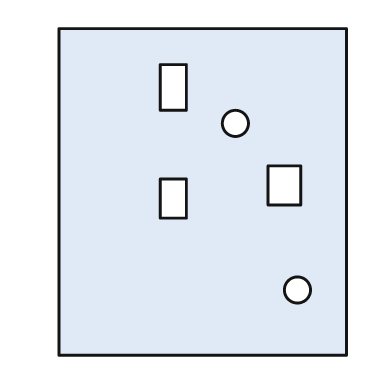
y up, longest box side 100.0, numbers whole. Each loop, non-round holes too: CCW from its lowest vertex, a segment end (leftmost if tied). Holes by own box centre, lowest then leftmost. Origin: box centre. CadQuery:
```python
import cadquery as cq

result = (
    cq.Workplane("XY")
    .moveTo(-44.0, -50.0)
    .lineTo(44.0, -50.0)
    .lineTo(44.0, 50.0)
    .lineTo(-44.0, 50.0)
    .close()
    .moveTo(29.0, -30.0)
    .circle(4.0)
    .moveTo(-13.0, -8.0)
    .lineTo(-5.0, -8.0)
    .lineTo(-5.0, 4.0)
    .lineTo(-13.0, 4.0)
    .close()
    .moveTo(20.0, -4.0)
    .lineTo(30.0, -4.0)
    .lineTo(30.0, 8.0)
    .lineTo(20.0, 8.0)
    .close()
    .moveTo(10.0, 21.0)
    .circle(4.0)
    .moveTo(-13.0, 25.0)
    .lineTo(-5.0, 25.0)
    .lineTo(-5.0, 39.0)
    .lineTo(-13.0, 39.0)
    .close()
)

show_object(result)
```